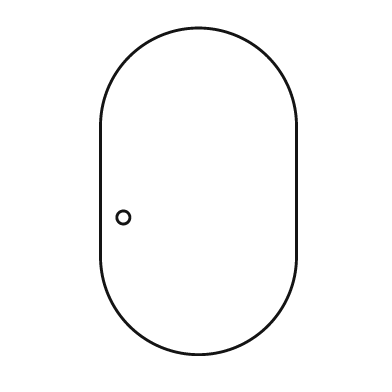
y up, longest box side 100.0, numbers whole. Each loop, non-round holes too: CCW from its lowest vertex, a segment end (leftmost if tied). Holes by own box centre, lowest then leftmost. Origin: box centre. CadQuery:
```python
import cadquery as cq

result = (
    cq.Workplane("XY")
    .moveTo(-30.0, -20.0)
    .threePointArc((0.0, -50.0), (30.0, -20.0))
    .lineTo(30.0, 20.0)
    .threePointArc((0.0, 50.0), (-30.0, 20.0))
    .close()
    .moveTo(-23.0, -8.0)
    .circle(2.0)
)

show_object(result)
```